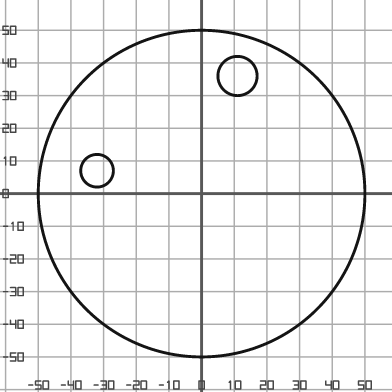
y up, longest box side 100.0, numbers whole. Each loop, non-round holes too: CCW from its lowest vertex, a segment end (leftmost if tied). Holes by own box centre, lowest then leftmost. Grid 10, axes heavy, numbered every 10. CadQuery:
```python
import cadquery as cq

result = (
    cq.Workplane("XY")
    .moveTo(0.0, 0.0)
    .circle(50.0)
    .moveTo(-32.0, 7.0)
    .circle(5.0)
    .moveTo(11.0, 36.0)
    .circle(6.0)
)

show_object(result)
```